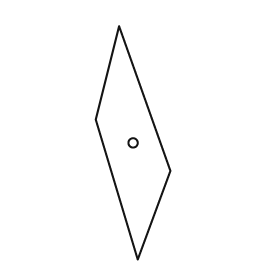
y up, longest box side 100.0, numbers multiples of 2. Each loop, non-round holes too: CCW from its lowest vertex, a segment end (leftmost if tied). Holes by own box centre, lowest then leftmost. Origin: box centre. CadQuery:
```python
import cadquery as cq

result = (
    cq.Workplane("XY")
    .moveTo(2.0, -50.0)
    .lineTo(16.0, -12.0)
    .lineTo(-6.0, 50.0)
    .lineTo(-16.0, 10.0)
    .close()
    .moveTo(0.0, 0.0)
    .circle(2.0)
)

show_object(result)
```